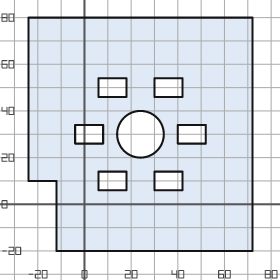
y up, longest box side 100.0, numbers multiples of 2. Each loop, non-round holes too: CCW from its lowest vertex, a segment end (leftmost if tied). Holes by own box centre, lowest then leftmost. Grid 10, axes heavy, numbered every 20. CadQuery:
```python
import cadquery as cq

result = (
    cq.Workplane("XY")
    .moveTo(-12.0, -20.0)
    .lineTo(72.0, -20.0)
    .lineTo(72.0, 80.0)
    .lineTo(-24.0, 80.0)
    .lineTo(-24.0, 10.0)
    .lineTo(-12.0, 10.0)
    .close()
    .moveTo(6.0, 6.0)
    .lineTo(18.0, 6.0)
    .lineTo(18.0, 14.0)
    .lineTo(6.0, 14.0)
    .close()
    .moveTo(30.0, 6.0)
    .lineTo(42.0, 6.0)
    .lineTo(42.0, 14.0)
    .lineTo(30.0, 14.0)
    .close()
    .moveTo(-4.0, 26.0)
    .lineTo(8.0, 26.0)
    .lineTo(8.0, 34.0)
    .lineTo(-4.0, 34.0)
    .close()
    .moveTo(24.0, 30.0)
    .circle(10.0)
    .moveTo(40.0, 26.0)
    .lineTo(52.0, 26.0)
    .lineTo(52.0, 34.0)
    .lineTo(40.0, 34.0)
    .close()
    .moveTo(6.0, 46.0)
    .lineTo(18.0, 46.0)
    .lineTo(18.0, 54.0)
    .lineTo(6.0, 54.0)
    .close()
    .moveTo(30.0, 46.0)
    .lineTo(42.0, 46.0)
    .lineTo(42.0, 54.0)
    .lineTo(30.0, 54.0)
    .close()
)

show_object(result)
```